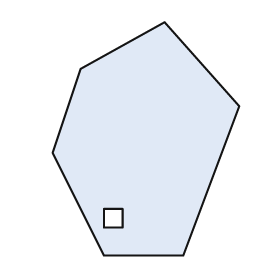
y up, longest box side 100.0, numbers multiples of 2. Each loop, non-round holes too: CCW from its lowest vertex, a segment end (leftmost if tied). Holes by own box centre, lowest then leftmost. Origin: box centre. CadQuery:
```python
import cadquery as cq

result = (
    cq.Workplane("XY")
    .moveTo(-18.0, -50.0)
    .lineTo(16.0, -50.0)
    .lineTo(40.0, 14.0)
    .lineTo(8.0, 50.0)
    .lineTo(-28.0, 30.0)
    .lineTo(-40.0, -6.0)
    .close()
    .moveTo(-18.0, -38.0)
    .lineTo(-10.0, -38.0)
    .lineTo(-10.0, -30.0)
    .lineTo(-18.0, -30.0)
    .close()
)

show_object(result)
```